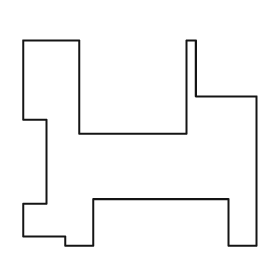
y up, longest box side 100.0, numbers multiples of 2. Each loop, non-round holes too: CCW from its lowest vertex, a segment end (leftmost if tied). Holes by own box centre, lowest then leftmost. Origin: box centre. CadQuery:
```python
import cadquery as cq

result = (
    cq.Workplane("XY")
    .moveTo(-32.0, -44.0)
    .lineTo(-20.0, -44.0)
    .lineTo(-20.0, -24.0)
    .lineTo(38.0, -24.0)
    .lineTo(38.0, -44.0)
    .lineTo(50.0, -44.0)
    .lineTo(50.0, 20.0)
    .lineTo(24.0, 20.0)
    .lineTo(24.0, 44.0)
    .lineTo(20.0, 44.0)
    .lineTo(20.0, 4.0)
    .lineTo(-26.0, 4.0)
    .lineTo(-26.0, 44.0)
    .lineTo(-50.0, 44.0)
    .lineTo(-50.0, 10.0)
    .lineTo(-40.0, 10.0)
    .lineTo(-40.0, -26.0)
    .lineTo(-50.0, -26.0)
    .lineTo(-50.0, -40.0)
    .lineTo(-32.0, -40.0)
    .close()
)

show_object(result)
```